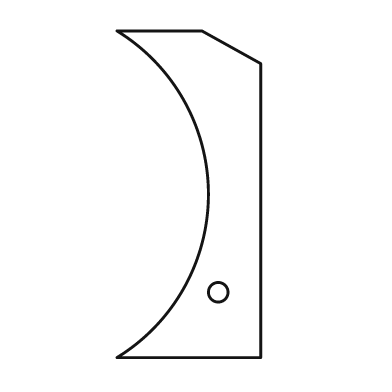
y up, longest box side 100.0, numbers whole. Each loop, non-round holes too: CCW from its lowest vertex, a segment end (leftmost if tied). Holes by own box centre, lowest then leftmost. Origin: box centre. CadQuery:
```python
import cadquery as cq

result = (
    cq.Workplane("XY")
    .moveTo(-22.0, -50.0)
    .lineTo(22.0, -50.0)
    .lineTo(22.0, 40.0)
    .lineTo(4.0, 50.0)
    .lineTo(-22.0, 50.0)
    .threePointArc((6.0, 0.0), (-22.0, -50.0))
    .close()
    .moveTo(9.0, -30.0)
    .circle(3.0)
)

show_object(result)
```